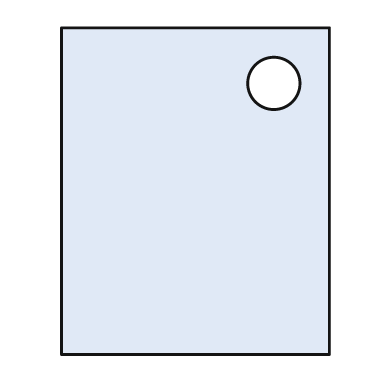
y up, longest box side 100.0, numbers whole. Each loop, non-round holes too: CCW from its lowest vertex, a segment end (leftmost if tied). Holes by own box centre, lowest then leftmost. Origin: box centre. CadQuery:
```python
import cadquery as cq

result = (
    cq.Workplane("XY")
    .moveTo(-41.0, -50.0)
    .lineTo(41.0, -50.0)
    .lineTo(41.0, 50.0)
    .lineTo(-41.0, 50.0)
    .close()
    .moveTo(24.0, 33.0)
    .circle(8.0)
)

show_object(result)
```